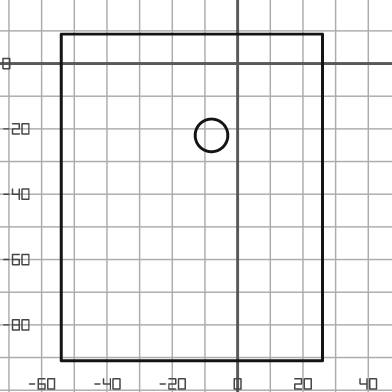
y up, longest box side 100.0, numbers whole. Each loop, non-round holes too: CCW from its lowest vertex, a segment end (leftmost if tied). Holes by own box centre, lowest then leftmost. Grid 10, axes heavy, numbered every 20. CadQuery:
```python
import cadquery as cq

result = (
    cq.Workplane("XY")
    .moveTo(-54.0, -91.0)
    .lineTo(26.0, -91.0)
    .lineTo(26.0, 9.0)
    .lineTo(-54.0, 9.0)
    .close()
    .moveTo(-8.0, -22.0)
    .circle(5.0)
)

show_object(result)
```